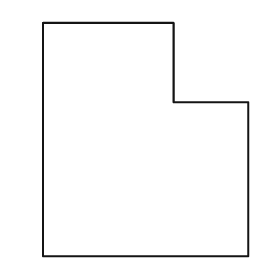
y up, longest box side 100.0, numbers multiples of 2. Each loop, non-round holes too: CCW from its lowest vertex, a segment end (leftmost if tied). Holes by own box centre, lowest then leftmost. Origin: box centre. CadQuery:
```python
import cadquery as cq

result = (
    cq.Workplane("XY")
    .moveTo(-44.0, -50.0)
    .lineTo(44.0, -50.0)
    .lineTo(44.0, 16.0)
    .lineTo(12.0, 16.0)
    .lineTo(12.0, 50.0)
    .lineTo(-44.0, 50.0)
    .close()
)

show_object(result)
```